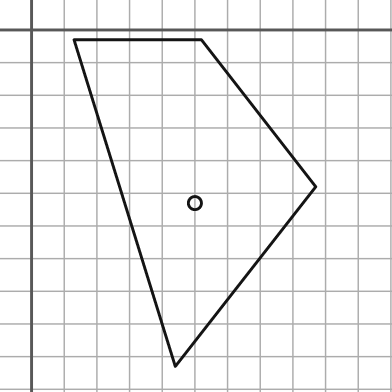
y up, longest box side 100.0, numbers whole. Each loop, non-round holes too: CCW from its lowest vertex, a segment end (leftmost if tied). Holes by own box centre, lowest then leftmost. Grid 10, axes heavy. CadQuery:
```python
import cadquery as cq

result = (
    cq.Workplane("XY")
    .moveTo(44.0, -103.0)
    .lineTo(87.0, -48.0)
    .lineTo(52.0, -3.0)
    .lineTo(13.0, -3.0)
    .close()
    .moveTo(50.0, -53.0)
    .circle(2.0)
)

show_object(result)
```